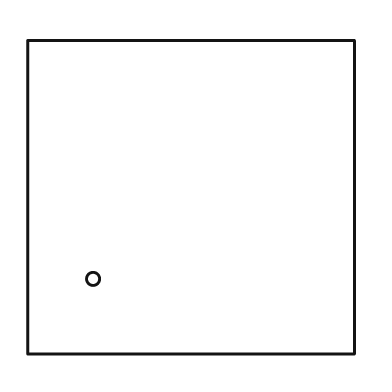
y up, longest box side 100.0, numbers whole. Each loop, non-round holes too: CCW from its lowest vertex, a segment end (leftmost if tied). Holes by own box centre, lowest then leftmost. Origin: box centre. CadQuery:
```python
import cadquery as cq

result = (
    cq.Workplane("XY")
    .moveTo(-50.0, -48.0)
    .lineTo(50.0, -48.0)
    .lineTo(50.0, 48.0)
    .lineTo(-50.0, 48.0)
    .close()
    .moveTo(-30.0, -25.0)
    .circle(2.0)
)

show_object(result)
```